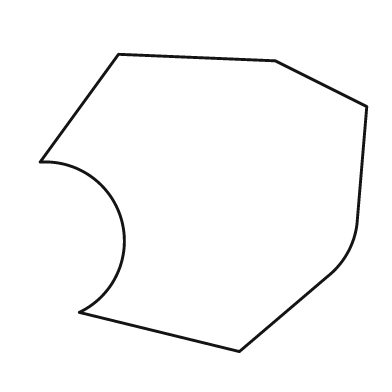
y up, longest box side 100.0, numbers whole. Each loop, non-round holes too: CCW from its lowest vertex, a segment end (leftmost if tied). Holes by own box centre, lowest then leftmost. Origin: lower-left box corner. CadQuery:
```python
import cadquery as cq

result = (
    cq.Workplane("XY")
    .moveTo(61.0, 0.0)
    .lineTo(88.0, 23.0)
    .threePointArc((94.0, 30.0), (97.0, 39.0))
    .lineTo(100.0, 75.0)
    .lineTo(72.0, 89.0)
    .lineTo(24.0, 91.0)
    .lineTo(0.0, 58.0)
    .threePointArc((25.0, 40.0), (12.0, 12.0))
    .close()
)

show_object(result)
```